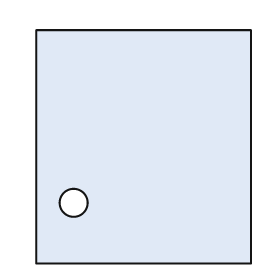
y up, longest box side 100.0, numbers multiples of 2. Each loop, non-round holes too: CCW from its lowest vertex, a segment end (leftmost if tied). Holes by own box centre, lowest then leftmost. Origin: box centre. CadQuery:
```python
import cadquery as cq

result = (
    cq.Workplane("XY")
    .moveTo(-46.0, -50.0)
    .lineTo(46.0, -50.0)
    .lineTo(46.0, 50.0)
    .lineTo(-46.0, 50.0)
    .close()
    .moveTo(-30.0, -24.0)
    .circle(6.0)
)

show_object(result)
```